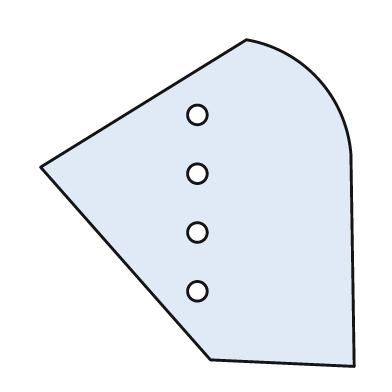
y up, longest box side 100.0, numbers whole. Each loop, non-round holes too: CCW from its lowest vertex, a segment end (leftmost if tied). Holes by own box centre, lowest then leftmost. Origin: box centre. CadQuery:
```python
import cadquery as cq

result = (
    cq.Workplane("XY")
    .moveTo(48.0, -50.0)
    .lineTo(47.0, 15.0)
    .threePointArc((37.0, 38.0), (15.0, 50.0))
    .lineTo(-48.0, 11.0)
    .lineTo(4.0, -48.0)
    .close()
    .moveTo(0.0, -27.0)
    .circle(3.0)
    .moveTo(0.0, -9.0)
    .circle(3.0)
    .moveTo(0.0, 9.0)
    .circle(3.0)
    .moveTo(0.0, 27.0)
    .circle(3.0)
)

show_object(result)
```